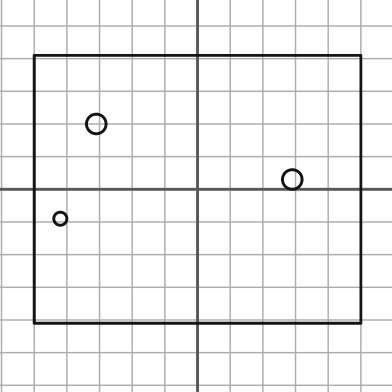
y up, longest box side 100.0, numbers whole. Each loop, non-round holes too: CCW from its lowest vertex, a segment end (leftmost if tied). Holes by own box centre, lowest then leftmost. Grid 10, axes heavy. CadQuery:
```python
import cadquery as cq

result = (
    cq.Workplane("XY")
    .moveTo(-50.0, -41.0)
    .lineTo(50.0, -41.0)
    .lineTo(50.0, 41.0)
    .lineTo(-50.0, 41.0)
    .close()
    .moveTo(-42.0, -9.0)
    .circle(2.0)
    .moveTo(29.0, 3.0)
    .circle(3.0)
    .moveTo(-31.0, 20.0)
    .circle(3.0)
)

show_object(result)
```